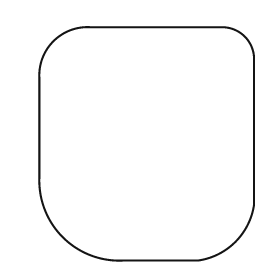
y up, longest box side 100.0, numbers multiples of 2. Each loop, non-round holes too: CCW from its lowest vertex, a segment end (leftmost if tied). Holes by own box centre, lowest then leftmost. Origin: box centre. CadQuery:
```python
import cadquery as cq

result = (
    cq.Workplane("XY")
    .moveTo(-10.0, -50.0)
    .lineTo(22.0, -50.0)
    .threePointArc((38.0, -42.0), (46.0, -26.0))
    .lineTo(46.0, 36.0)
    .threePointArc((42.0, 46.0), (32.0, 50.0))
    .lineTo(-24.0, 50.0)
    .threePointArc((-40.0, 44.0), (-46.0, 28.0))
    .lineTo(-46.0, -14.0)
    .threePointArc((-36.0, -40.0), (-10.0, -50.0))
    .close()
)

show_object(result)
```